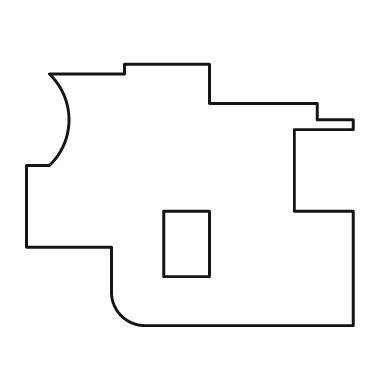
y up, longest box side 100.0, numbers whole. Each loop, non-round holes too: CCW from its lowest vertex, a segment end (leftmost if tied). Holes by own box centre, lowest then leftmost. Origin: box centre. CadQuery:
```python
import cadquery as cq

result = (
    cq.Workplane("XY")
    .moveTo(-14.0, -40.0)
    .lineTo(50.0, -40.0)
    .lineTo(50.0, -5.0)
    .lineTo(32.0, -5.0)
    .lineTo(32.0, 20.0)
    .lineTo(50.0, 20.0)
    .lineTo(50.0, 23.0)
    .lineTo(39.0, 23.0)
    .lineTo(39.0, 28.0)
    .lineTo(6.0, 28.0)
    .lineTo(6.0, 40.0)
    .lineTo(-20.0, 40.0)
    .lineTo(-20.0, 37.0)
    .lineTo(-43.0, 37.0)
    .threePointArc((-37.0, 23.0), (-43.0, 9.0))
    .lineTo(-50.0, 9.0)
    .lineTo(-50.0, -16.0)
    .lineTo(-24.0, -16.0)
    .lineTo(-24.0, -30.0)
    .threePointArc((-21.0, -37.0), (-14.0, -40.0))
    .close()
    .moveTo(-8.0, -25.0)
    .lineTo(6.0, -25.0)
    .lineTo(6.0, -5.0)
    .lineTo(-8.0, -5.0)
    .close()
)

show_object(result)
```